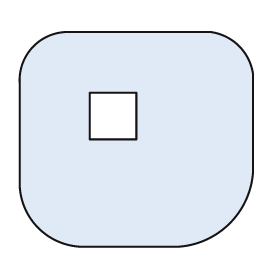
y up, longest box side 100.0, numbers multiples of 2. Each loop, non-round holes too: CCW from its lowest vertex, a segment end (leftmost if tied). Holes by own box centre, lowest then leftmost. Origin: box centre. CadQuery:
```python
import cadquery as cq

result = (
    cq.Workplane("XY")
    .moveTo(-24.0, -46.0)
    .lineTo(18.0, -46.0)
    .threePointArc((40.0, -36.0), (50.0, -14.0))
    .lineTo(50.0, 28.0)
    .threePointArc((44.0, 40.0), (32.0, 46.0))
    .lineTo(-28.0, 46.0)
    .threePointArc((-44.0, 40.0), (-50.0, 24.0))
    .lineTo(-50.0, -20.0)
    .threePointArc((-42.0, -38.0), (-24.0, -46.0))
    .close()
    .moveTo(-20.0, 0.0)
    .lineTo(0.0, 0.0)
    .lineTo(0.0, 20.0)
    .lineTo(-20.0, 20.0)
    .close()
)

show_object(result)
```